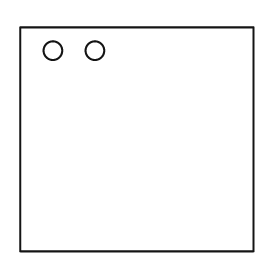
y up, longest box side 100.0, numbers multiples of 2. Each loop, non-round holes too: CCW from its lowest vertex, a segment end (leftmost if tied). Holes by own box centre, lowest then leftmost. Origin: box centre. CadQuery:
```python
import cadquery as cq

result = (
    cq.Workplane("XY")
    .moveTo(-50.0, -48.0)
    .lineTo(50.0, -48.0)
    .lineTo(50.0, 48.0)
    .lineTo(-50.0, 48.0)
    .close()
    .moveTo(-36.0, 38.0)
    .circle(4.0)
    .moveTo(-18.0, 38.0)
    .circle(4.0)
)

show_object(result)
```